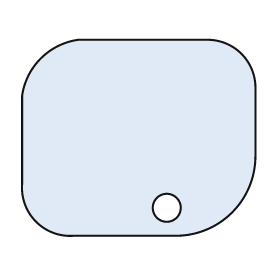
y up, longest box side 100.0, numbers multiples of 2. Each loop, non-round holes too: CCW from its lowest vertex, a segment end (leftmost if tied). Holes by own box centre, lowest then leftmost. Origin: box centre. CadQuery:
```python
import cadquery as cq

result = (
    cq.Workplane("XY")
    .moveTo(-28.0, -42.0)
    .lineTo(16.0, -42.0)
    .threePointArc((40.0, -32.0), (50.0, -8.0))
    .lineTo(50.0, 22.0)
    .threePointArc((44.0, 36.0), (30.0, 42.0))
    .lineTo(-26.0, 42.0)
    .threePointArc((-42.0, 34.0), (-50.0, 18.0))
    .lineTo(-50.0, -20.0)
    .threePointArc((-44.0, -36.0), (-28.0, -42.0))
    .close()
    .moveTo(12.0, -30.0)
    .circle(6.0)
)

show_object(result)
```